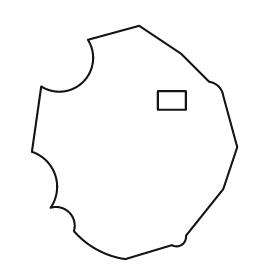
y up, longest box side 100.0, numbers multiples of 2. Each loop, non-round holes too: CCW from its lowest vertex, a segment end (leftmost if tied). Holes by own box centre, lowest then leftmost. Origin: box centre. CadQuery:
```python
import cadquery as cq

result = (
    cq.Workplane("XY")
    .moveTo(-4.0, -50.0)
    .lineTo(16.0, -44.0)
    .threePointArc((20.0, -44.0), (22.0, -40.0))
    .lineTo(38.0, -20.0)
    .lineTo(44.0, -2.0)
    .lineTo(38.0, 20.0)
    .threePointArc((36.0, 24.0), (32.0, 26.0))
    .lineTo(20.0, 38.0)
    .lineTo(2.0, 50.0)
    .lineTo(-20.0, 44.0)
    .threePointArc((-22.0, 26.0), (-40.0, 24.0))
    .lineTo(-44.0, -4.0)
    .threePointArc((-34.0, -14.0), (-36.0, -28.0))
    .threePointArc((-28.0, -30.0), (-26.0, -38.0))
    .threePointArc((-16.0, -46.0), (-4.0, -50.0))
    .close()
    .moveTo(10.0, 14.0)
    .lineTo(22.0, 14.0)
    .lineTo(22.0, 22.0)
    .lineTo(10.0, 22.0)
    .close()
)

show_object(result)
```